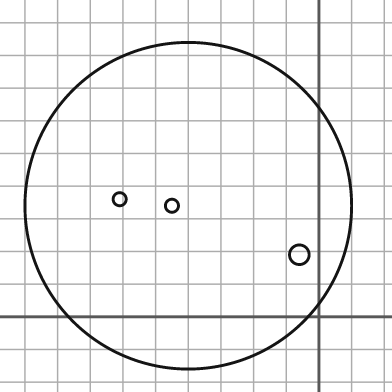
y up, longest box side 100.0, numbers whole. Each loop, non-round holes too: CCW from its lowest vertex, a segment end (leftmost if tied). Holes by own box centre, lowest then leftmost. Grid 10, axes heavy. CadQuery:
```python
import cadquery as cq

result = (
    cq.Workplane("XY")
    .moveTo(-40.0, 34.0)
    .circle(50.0)
    .moveTo(-6.0, 19.0)
    .circle(3.0)
    .moveTo(-45.0, 34.0)
    .circle(2.0)
    .moveTo(-61.0, 36.0)
    .circle(2.0)
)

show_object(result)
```